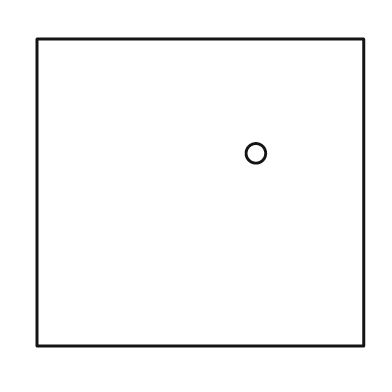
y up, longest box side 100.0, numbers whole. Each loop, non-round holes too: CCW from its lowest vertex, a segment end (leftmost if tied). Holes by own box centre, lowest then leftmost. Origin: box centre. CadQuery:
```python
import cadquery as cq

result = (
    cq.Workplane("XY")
    .moveTo(-50.0, -47.0)
    .lineTo(50.0, -47.0)
    .lineTo(50.0, 47.0)
    .lineTo(-50.0, 47.0)
    .close()
    .moveTo(17.0, 12.0)
    .circle(3.0)
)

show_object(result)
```